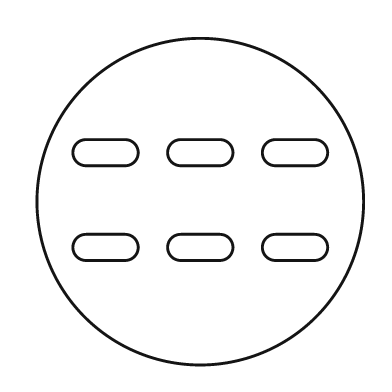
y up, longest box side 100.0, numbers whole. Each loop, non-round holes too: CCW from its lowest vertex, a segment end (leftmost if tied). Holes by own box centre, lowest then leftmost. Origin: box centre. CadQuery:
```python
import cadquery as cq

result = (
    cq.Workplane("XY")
    .moveTo(0.0, 0.0)
    .circle(50.0)
    .moveTo(-35.0, -18.0)
    .lineTo(-23.0, -18.0)
    .threePointArc((-19.0, -14.0), (-23.0, -10.0))
    .lineTo(-35.0, -10.0)
    .threePointArc((-39.0, -14.0), (-35.0, -18.0))
    .close()
    .moveTo(-6.0, -18.0)
    .lineTo(6.0, -18.0)
    .threePointArc((10.0, -14.0), (6.0, -10.0))
    .lineTo(-6.0, -10.0)
    .threePointArc((-10.0, -14.0), (-6.0, -18.0))
    .close()
    .moveTo(23.0, -18.0)
    .lineTo(35.0, -18.0)
    .threePointArc((39.0, -14.0), (35.0, -10.0))
    .lineTo(23.0, -10.0)
    .threePointArc((19.0, -14.0), (23.0, -18.0))
    .close()
    .moveTo(-35.0, 11.0)
    .lineTo(-23.0, 11.0)
    .threePointArc((-19.0, 15.0), (-23.0, 19.0))
    .lineTo(-35.0, 19.0)
    .threePointArc((-39.0, 15.0), (-35.0, 11.0))
    .close()
    .moveTo(-6.0, 11.0)
    .lineTo(6.0, 11.0)
    .threePointArc((10.0, 15.0), (6.0, 19.0))
    .lineTo(-6.0, 19.0)
    .threePointArc((-10.0, 15.0), (-6.0, 11.0))
    .close()
    .moveTo(23.0, 11.0)
    .lineTo(35.0, 11.0)
    .threePointArc((39.0, 15.0), (35.0, 19.0))
    .lineTo(23.0, 19.0)
    .threePointArc((19.0, 15.0), (23.0, 11.0))
    .close()
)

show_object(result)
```